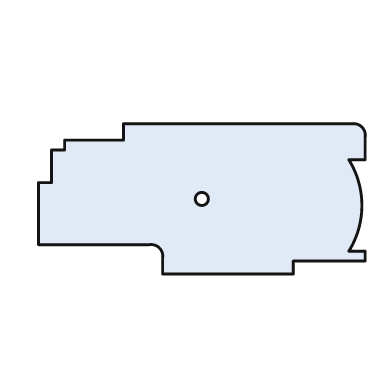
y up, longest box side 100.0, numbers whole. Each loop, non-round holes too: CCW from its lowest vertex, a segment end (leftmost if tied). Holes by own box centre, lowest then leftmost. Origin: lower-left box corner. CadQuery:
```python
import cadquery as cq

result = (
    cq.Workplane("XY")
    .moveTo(38.0, 0.0)
    .lineTo(78.0, 0.0)
    .lineTo(78.0, 4.0)
    .lineTo(100.0, 4.0)
    .lineTo(100.0, 7.0)
    .lineTo(95.0, 7.0)
    .threePointArc((99.0, 21.0), (95.0, 35.0))
    .lineTo(100.0, 35.0)
    .lineTo(100.0, 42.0)
    .threePointArc((99.0, 45.0), (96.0, 46.0))
    .lineTo(26.0, 46.0)
    .lineTo(26.0, 41.0)
    .lineTo(8.0, 41.0)
    .lineTo(8.0, 38.0)
    .lineTo(4.0, 38.0)
    .lineTo(4.0, 28.0)
    .lineTo(0.0, 28.0)
    .lineTo(0.0, 9.0)
    .lineTo(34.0, 9.0)
    .threePointArc((37.0, 8.0), (38.0, 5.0))
    .close()
    .moveTo(50.0, 23.0)
    .circle(2.0)
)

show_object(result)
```